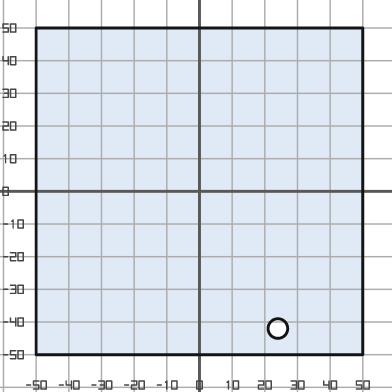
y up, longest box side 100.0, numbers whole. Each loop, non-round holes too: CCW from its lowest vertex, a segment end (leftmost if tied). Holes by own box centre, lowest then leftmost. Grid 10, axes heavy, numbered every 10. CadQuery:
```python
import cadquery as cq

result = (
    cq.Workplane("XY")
    .moveTo(-50.0, -50.0)
    .lineTo(50.0, -50.0)
    .lineTo(50.0, 50.0)
    .lineTo(-50.0, 50.0)
    .close()
    .moveTo(24.0, -42.0)
    .circle(3.0)
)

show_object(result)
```